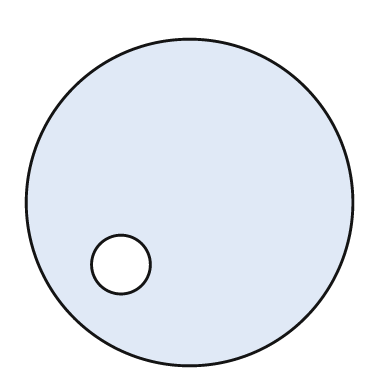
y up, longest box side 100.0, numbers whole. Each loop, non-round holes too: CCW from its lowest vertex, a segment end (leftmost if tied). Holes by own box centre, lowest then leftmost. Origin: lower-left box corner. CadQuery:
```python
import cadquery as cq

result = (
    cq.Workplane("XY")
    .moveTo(50.0, 50.0)
    .circle(50.0)
    .moveTo(29.0, 31.0)
    .circle(9.0)
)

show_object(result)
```